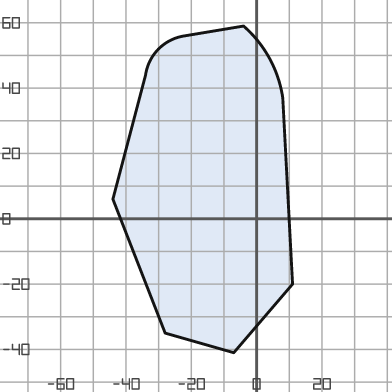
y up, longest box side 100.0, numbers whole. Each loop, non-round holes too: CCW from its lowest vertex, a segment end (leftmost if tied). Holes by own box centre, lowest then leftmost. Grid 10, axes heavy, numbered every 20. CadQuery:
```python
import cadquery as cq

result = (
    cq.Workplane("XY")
    .moveTo(-7.0, -41.0)
    .lineTo(11.0, -20.0)
    .lineTo(8.0, 37.0)
    .threePointArc((4.0, 49.0), (-4.0, 59.0))
    .lineTo(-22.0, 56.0)
    .threePointArc((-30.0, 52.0), (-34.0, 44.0))
    .lineTo(-44.0, 6.0)
    .lineTo(-28.0, -35.0)
    .close()
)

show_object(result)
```